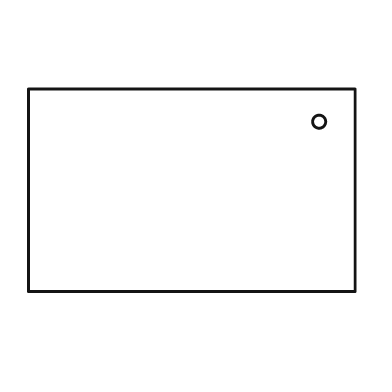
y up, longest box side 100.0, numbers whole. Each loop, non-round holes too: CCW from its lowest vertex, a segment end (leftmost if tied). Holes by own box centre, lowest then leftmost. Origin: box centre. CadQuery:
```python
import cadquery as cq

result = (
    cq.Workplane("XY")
    .moveTo(-50.0, -31.0)
    .lineTo(50.0, -31.0)
    .lineTo(50.0, 31.0)
    .lineTo(-50.0, 31.0)
    .close()
    .moveTo(39.0, 21.0)
    .circle(2.0)
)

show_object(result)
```